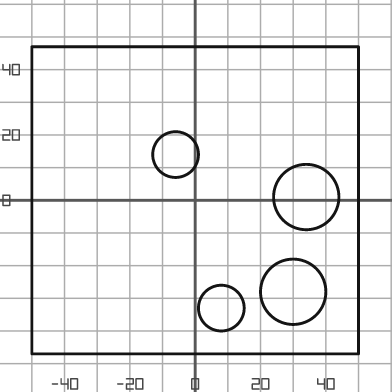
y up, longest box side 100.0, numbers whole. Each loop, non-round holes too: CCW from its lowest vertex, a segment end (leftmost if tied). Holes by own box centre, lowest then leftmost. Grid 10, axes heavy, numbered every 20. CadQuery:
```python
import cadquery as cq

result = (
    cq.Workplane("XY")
    .moveTo(-50.0, -47.0)
    .lineTo(50.0, -47.0)
    .lineTo(50.0, 47.0)
    .lineTo(-50.0, 47.0)
    .close()
    .moveTo(8.0, -33.0)
    .circle(7.0)
    .moveTo(30.0, -28.0)
    .circle(10.0)
    .moveTo(34.0, 1.0)
    .circle(10.0)
    .moveTo(-6.0, 14.0)
    .circle(7.0)
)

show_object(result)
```